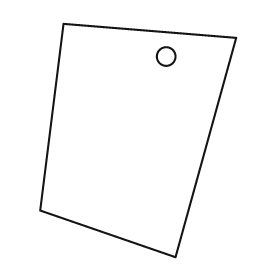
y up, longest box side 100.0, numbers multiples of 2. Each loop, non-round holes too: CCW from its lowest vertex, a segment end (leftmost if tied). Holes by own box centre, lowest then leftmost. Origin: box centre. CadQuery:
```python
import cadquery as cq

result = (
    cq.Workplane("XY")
    .moveTo(16.0, -50.0)
    .lineTo(42.0, 44.0)
    .lineTo(-32.0, 50.0)
    .lineTo(-42.0, -30.0)
    .close()
    .moveTo(12.0, 36.0)
    .circle(4.0)
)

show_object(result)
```